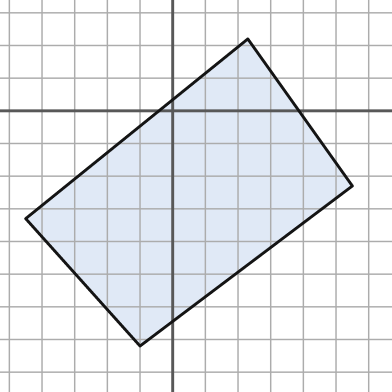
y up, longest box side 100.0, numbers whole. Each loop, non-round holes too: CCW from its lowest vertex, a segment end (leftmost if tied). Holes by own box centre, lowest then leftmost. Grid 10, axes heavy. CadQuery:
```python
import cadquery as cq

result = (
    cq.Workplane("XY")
    .moveTo(-10.0, -72.0)
    .lineTo(55.0, -23.0)
    .lineTo(23.0, 22.0)
    .lineTo(-45.0, -33.0)
    .close()
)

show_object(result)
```